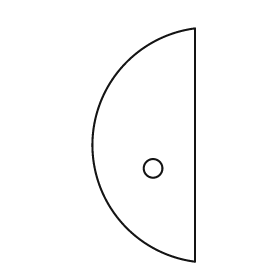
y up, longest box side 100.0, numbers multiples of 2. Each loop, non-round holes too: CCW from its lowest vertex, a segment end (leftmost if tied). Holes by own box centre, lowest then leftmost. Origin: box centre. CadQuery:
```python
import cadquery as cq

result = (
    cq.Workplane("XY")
    .moveTo(22.0, -50.0)
    .lineTo(22.0, 50.0)
    .threePointArc((-22.0, 0.0), (22.0, -50.0))
    .close()
    .moveTo(4.0, -10.0)
    .circle(4.0)
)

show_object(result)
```